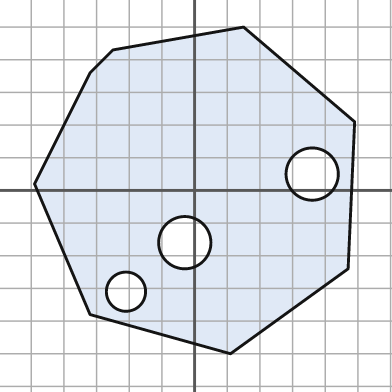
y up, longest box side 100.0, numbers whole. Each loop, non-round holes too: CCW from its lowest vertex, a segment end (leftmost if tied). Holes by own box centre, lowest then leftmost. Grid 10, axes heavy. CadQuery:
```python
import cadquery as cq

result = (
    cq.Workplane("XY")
    .moveTo(11.0, -50.0)
    .lineTo(47.0, -24.0)
    .lineTo(49.0, 21.0)
    .lineTo(15.0, 50.0)
    .lineTo(-25.0, 43.0)
    .lineTo(-32.0, 36.0)
    .lineTo(-49.0, 2.0)
    .lineTo(-32.0, -38.0)
    .close()
    .moveTo(-21.0, -31.0)
    .circle(6.0)
    .moveTo(-3.0, -16.0)
    .circle(8.0)
    .moveTo(36.0, 5.0)
    .circle(8.0)
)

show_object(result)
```